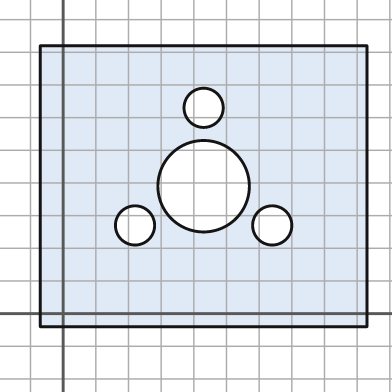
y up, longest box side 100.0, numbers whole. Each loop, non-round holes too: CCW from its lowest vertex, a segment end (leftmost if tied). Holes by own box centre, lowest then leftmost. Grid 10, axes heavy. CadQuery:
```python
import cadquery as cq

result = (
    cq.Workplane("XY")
    .moveTo(-7.0, -4.0)
    .lineTo(93.0, -4.0)
    .lineTo(93.0, 82.0)
    .lineTo(-7.0, 82.0)
    .close()
    .moveTo(22.0, 27.0)
    .circle(6.0)
    .moveTo(64.0, 27.0)
    .circle(6.0)
    .moveTo(43.0, 39.0)
    .circle(14.0)
    .moveTo(43.0, 63.0)
    .circle(6.0)
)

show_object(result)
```